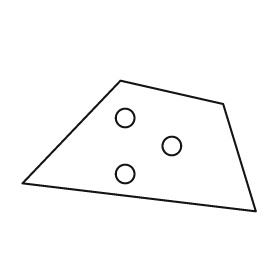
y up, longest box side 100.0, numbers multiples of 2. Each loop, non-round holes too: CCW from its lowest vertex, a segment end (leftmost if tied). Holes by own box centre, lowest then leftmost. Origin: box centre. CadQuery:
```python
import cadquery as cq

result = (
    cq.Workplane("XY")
    .moveTo(50.0, -28.0)
    .lineTo(36.0, 18.0)
    .lineTo(-8.0, 28.0)
    .lineTo(-50.0, -16.0)
    .close()
    .moveTo(-6.0, -12.0)
    .circle(4.0)
    .moveTo(14.0, 0.0)
    .circle(4.0)
    .moveTo(-6.0, 12.0)
    .circle(4.0)
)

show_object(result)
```